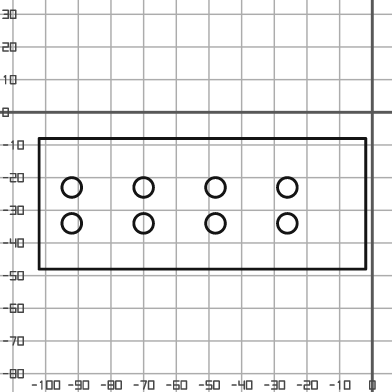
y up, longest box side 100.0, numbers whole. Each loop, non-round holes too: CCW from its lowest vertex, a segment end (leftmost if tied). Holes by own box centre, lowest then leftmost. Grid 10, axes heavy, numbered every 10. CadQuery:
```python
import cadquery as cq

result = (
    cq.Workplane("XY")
    .moveTo(-102.0, -48.0)
    .lineTo(-2.0, -48.0)
    .lineTo(-2.0, -8.0)
    .lineTo(-102.0, -8.0)
    .close()
    .moveTo(-92.0, -34.0)
    .circle(3.0)
    .moveTo(-70.0, -34.0)
    .circle(3.0)
    .moveTo(-48.0, -34.0)
    .circle(3.0)
    .moveTo(-26.0, -34.0)
    .circle(3.0)
    .moveTo(-92.0, -23.0)
    .circle(3.0)
    .moveTo(-70.0, -23.0)
    .circle(3.0)
    .moveTo(-48.0, -23.0)
    .circle(3.0)
    .moveTo(-26.0, -23.0)
    .circle(3.0)
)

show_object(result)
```